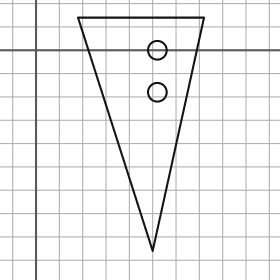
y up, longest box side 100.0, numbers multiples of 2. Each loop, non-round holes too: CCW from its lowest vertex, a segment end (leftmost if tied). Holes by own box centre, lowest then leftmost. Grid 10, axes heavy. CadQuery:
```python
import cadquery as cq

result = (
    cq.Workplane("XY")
    .moveTo(50.0, -86.0)
    .lineTo(72.0, 14.0)
    .lineTo(18.0, 14.0)
    .close()
    .moveTo(52.0, -18.0)
    .circle(4.0)
    .moveTo(52.0, 0.0)
    .circle(4.0)
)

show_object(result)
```